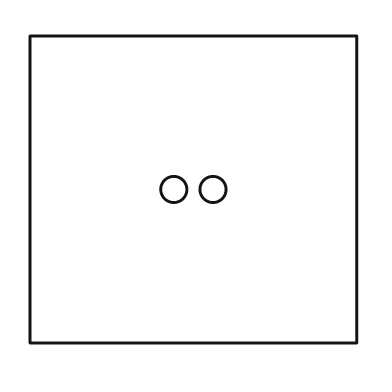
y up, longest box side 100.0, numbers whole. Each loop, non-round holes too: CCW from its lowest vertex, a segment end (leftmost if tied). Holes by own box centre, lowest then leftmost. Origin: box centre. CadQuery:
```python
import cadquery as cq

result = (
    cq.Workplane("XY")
    .moveTo(-50.0, -47.0)
    .lineTo(50.0, -47.0)
    .lineTo(50.0, 47.0)
    .lineTo(-50.0, 47.0)
    .close()
    .moveTo(-6.0, 0.0)
    .circle(4.0)
    .moveTo(6.0, 0.0)
    .circle(4.0)
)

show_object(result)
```